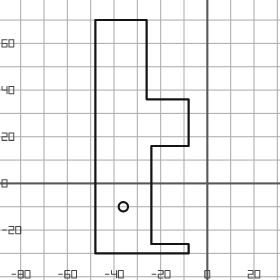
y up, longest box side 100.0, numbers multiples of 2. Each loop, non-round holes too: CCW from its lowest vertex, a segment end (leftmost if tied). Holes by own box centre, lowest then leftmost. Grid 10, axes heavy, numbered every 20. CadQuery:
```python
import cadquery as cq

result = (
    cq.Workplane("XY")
    .moveTo(-48.0, -30.0)
    .lineTo(-8.0, -30.0)
    .lineTo(-8.0, -26.0)
    .lineTo(-24.0, -26.0)
    .lineTo(-24.0, 16.0)
    .lineTo(-8.0, 16.0)
    .lineTo(-8.0, 36.0)
    .lineTo(-26.0, 36.0)
    .lineTo(-26.0, 70.0)
    .lineTo(-48.0, 70.0)
    .close()
    .moveTo(-36.0, -10.0)
    .circle(2.0)
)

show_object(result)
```